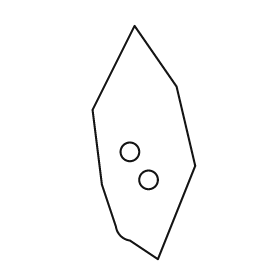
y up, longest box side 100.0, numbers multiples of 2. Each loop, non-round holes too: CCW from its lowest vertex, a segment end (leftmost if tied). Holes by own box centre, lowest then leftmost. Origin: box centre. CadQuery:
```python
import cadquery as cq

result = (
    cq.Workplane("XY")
    .moveTo(6.0, -50.0)
    .lineTo(22.0, -10.0)
    .lineTo(14.0, 24.0)
    .lineTo(-4.0, 50.0)
    .lineTo(-22.0, 14.0)
    .lineTo(-18.0, -18.0)
    .lineTo(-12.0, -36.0)
    .threePointArc((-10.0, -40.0), (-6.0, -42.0))
    .close()
    .moveTo(2.0, -16.0)
    .circle(4.0)
    .moveTo(-6.0, -4.0)
    .circle(4.0)
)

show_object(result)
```